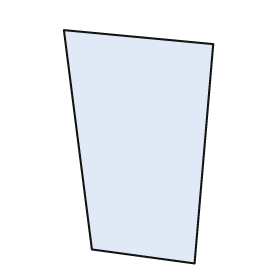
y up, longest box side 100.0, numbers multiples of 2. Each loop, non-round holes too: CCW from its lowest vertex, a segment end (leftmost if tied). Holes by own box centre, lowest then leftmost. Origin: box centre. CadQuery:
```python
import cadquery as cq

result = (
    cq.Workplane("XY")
    .moveTo(24.0, -50.0)
    .lineTo(32.0, 44.0)
    .lineTo(-32.0, 50.0)
    .lineTo(-20.0, -44.0)
    .close()
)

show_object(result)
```